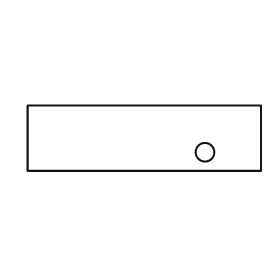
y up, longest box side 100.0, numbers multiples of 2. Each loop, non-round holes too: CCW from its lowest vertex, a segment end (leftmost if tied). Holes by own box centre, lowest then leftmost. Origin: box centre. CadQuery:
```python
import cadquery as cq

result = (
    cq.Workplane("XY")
    .moveTo(-50.0, -14.0)
    .lineTo(50.0, -14.0)
    .lineTo(50.0, 14.0)
    .lineTo(-50.0, 14.0)
    .close()
    .moveTo(26.0, -6.0)
    .circle(4.0)
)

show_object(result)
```